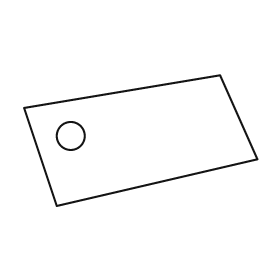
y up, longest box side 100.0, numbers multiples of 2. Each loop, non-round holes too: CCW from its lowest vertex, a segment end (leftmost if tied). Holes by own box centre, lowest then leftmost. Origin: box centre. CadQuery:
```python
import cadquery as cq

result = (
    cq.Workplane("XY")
    .moveTo(-36.0, -28.0)
    .lineTo(50.0, -8.0)
    .lineTo(34.0, 28.0)
    .lineTo(-50.0, 14.0)
    .close()
    .moveTo(-30.0, 2.0)
    .circle(6.0)
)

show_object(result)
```